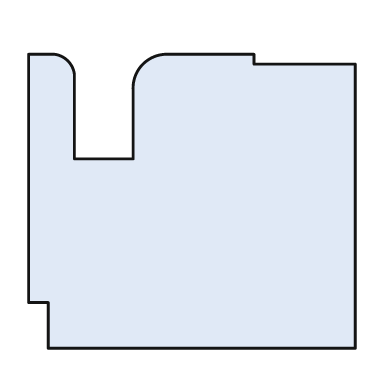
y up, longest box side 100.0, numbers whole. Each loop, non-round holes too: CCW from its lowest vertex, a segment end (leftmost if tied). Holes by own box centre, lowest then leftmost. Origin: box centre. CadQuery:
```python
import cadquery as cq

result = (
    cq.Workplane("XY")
    .moveTo(-44.0, -45.0)
    .lineTo(50.0, -45.0)
    .lineTo(50.0, 42.0)
    .lineTo(19.0, 42.0)
    .lineTo(19.0, 45.0)
    .lineTo(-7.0, 45.0)
    .threePointArc((-15.0, 42.0), (-18.0, 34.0))
    .lineTo(-18.0, 13.0)
    .lineTo(-36.0, 13.0)
    .lineTo(-36.0, 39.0)
    .threePointArc((-38.0, 43.0), (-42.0, 45.0))
    .lineTo(-50.0, 45.0)
    .lineTo(-50.0, -31.0)
    .lineTo(-44.0, -31.0)
    .close()
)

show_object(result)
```